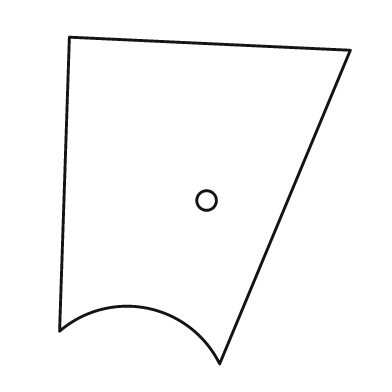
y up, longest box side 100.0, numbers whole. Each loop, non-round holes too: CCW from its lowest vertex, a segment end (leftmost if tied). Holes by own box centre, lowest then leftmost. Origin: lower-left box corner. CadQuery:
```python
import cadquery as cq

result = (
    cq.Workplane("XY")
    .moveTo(49.0, 0.0)
    .lineTo(89.0, 96.0)
    .lineTo(3.0, 100.0)
    .lineTo(0.0, 10.0)
    .threePointArc((27.0, 17.0), (49.0, 0.0))
    .close()
    .moveTo(45.0, 50.0)
    .circle(3.0)
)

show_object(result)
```